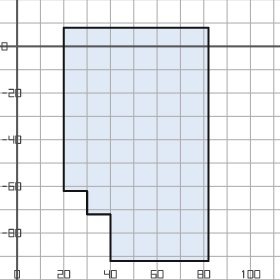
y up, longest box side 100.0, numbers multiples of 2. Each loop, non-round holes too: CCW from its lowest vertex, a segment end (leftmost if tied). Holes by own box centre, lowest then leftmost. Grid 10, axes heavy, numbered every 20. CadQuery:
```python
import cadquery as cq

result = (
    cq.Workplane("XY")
    .moveTo(40.0, -92.0)
    .lineTo(82.0, -92.0)
    .lineTo(82.0, 8.0)
    .lineTo(20.0, 8.0)
    .lineTo(20.0, -62.0)
    .lineTo(30.0, -62.0)
    .lineTo(30.0, -72.0)
    .lineTo(40.0, -72.0)
    .close()
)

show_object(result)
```